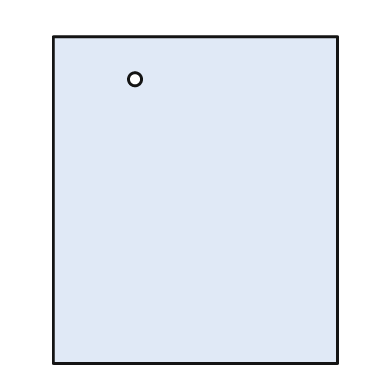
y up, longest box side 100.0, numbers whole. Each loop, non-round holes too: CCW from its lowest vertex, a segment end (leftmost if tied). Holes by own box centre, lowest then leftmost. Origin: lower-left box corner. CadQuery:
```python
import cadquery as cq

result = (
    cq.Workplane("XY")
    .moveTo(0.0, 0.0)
    .lineTo(87.0, 0.0)
    .lineTo(87.0, 100.0)
    .lineTo(0.0, 100.0)
    .close()
    .moveTo(25.0, 87.0)
    .circle(2.0)
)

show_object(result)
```